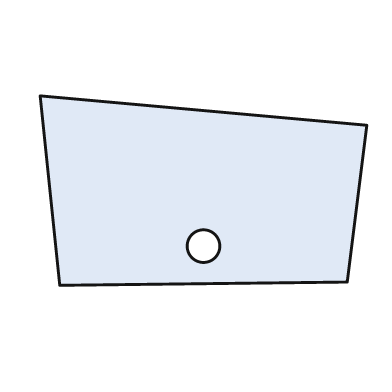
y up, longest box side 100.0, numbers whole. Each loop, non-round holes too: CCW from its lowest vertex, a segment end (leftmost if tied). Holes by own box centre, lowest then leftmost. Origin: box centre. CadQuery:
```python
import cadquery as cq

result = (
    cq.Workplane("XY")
    .moveTo(-44.0, -29.0)
    .lineTo(44.0, -28.0)
    .lineTo(50.0, 20.0)
    .lineTo(-50.0, 29.0)
    .close()
    .moveTo(0.0, -17.0)
    .circle(5.0)
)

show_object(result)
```